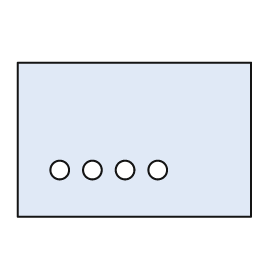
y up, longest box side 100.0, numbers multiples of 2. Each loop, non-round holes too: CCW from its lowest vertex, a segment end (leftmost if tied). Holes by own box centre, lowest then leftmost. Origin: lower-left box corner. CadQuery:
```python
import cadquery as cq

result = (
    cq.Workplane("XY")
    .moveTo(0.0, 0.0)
    .lineTo(100.0, 0.0)
    .lineTo(100.0, 66.0)
    .lineTo(0.0, 66.0)
    .close()
    .moveTo(18.0, 20.0)
    .circle(4.0)
    .moveTo(32.0, 20.0)
    .circle(4.0)
    .moveTo(46.0, 20.0)
    .circle(4.0)
    .moveTo(60.0, 20.0)
    .circle(4.0)
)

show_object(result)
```